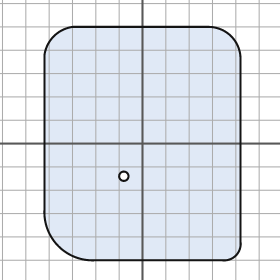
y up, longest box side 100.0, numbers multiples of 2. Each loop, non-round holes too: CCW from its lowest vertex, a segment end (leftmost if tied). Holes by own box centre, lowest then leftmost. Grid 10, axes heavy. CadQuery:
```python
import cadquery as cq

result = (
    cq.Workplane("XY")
    .moveTo(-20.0, -50.0)
    .lineTo(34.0, -50.0)
    .threePointArc((40.0, -48.0), (42.0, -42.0))
    .lineTo(42.0, 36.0)
    .threePointArc((38.0, 46.0), (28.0, 50.0))
    .lineTo(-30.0, 50.0)
    .threePointArc((-38.0, 46.0), (-42.0, 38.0))
    .lineTo(-42.0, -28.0)
    .threePointArc((-36.0, -44.0), (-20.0, -50.0))
    .close()
    .moveTo(-8.0, -14.0)
    .circle(2.0)
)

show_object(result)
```